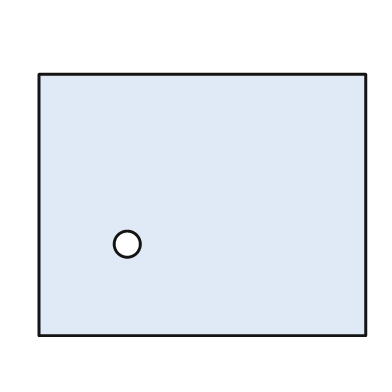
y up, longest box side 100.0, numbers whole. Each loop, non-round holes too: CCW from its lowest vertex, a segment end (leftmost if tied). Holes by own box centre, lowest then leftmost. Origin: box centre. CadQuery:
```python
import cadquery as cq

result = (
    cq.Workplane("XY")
    .moveTo(-50.0, -40.0)
    .lineTo(50.0, -40.0)
    .lineTo(50.0, 40.0)
    .lineTo(-50.0, 40.0)
    .close()
    .moveTo(-23.0, -12.0)
    .circle(4.0)
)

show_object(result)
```